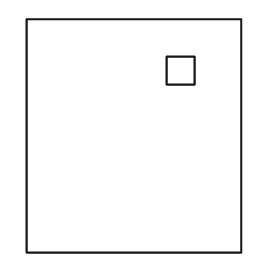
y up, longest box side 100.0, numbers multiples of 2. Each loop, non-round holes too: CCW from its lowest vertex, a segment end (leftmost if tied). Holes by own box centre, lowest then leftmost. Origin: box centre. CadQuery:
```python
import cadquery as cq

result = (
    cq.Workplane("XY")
    .moveTo(-46.0, -50.0)
    .lineTo(46.0, -50.0)
    .lineTo(46.0, 50.0)
    .lineTo(-46.0, 50.0)
    .close()
    .moveTo(14.0, 22.0)
    .lineTo(26.0, 22.0)
    .lineTo(26.0, 34.0)
    .lineTo(14.0, 34.0)
    .close()
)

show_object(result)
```